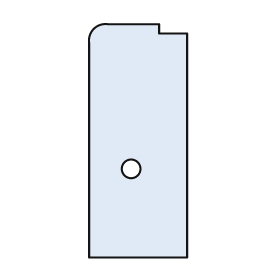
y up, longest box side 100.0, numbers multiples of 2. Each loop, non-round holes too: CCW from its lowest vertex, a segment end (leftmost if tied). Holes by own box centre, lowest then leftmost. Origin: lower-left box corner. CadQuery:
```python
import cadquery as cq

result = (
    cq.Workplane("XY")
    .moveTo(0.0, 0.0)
    .lineTo(42.0, 0.0)
    .lineTo(42.0, 96.0)
    .lineTo(30.0, 96.0)
    .lineTo(30.0, 100.0)
    .lineTo(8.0, 100.0)
    .threePointArc((2.0, 98.0), (0.0, 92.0))
    .close()
    .moveTo(18.0, 38.0)
    .circle(4.0)
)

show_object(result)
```